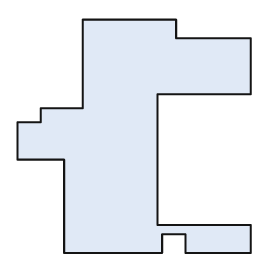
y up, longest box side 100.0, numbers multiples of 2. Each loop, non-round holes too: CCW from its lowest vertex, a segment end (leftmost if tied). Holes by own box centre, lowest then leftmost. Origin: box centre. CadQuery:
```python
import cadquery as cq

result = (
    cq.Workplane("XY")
    .moveTo(-30.0, -50.0)
    .lineTo(12.0, -50.0)
    .lineTo(12.0, -42.0)
    .lineTo(22.0, -42.0)
    .lineTo(22.0, -50.0)
    .lineTo(50.0, -50.0)
    .lineTo(50.0, -38.0)
    .lineTo(10.0, -38.0)
    .lineTo(10.0, 18.0)
    .lineTo(50.0, 18.0)
    .lineTo(50.0, 42.0)
    .lineTo(18.0, 42.0)
    .lineTo(18.0, 50.0)
    .lineTo(-22.0, 50.0)
    .lineTo(-22.0, 12.0)
    .lineTo(-40.0, 12.0)
    .lineTo(-40.0, 6.0)
    .lineTo(-50.0, 6.0)
    .lineTo(-50.0, -10.0)
    .lineTo(-30.0, -10.0)
    .close()
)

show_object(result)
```